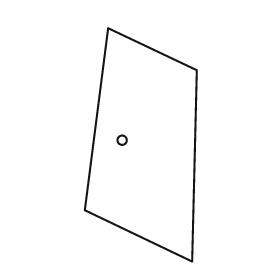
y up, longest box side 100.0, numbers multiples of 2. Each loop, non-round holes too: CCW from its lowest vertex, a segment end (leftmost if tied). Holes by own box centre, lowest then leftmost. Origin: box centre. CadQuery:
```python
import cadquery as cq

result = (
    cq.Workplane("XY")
    .moveTo(22.0, -50.0)
    .lineTo(24.0, 32.0)
    .lineTo(-14.0, 50.0)
    .lineTo(-24.0, -28.0)
    .close()
    .moveTo(-8.0, 2.0)
    .circle(2.0)
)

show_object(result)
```